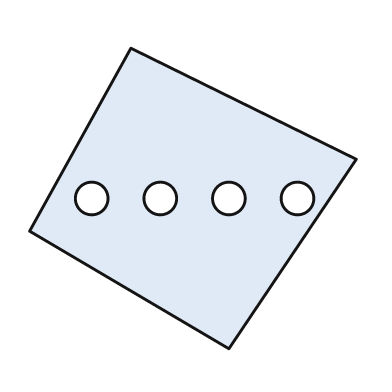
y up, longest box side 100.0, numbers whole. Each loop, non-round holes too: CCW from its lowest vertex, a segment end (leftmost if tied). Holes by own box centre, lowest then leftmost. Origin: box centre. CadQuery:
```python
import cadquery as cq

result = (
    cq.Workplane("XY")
    .moveTo(11.0, -46.0)
    .lineTo(50.0, 12.0)
    .lineTo(-19.0, 46.0)
    .lineTo(-50.0, -10.0)
    .close()
    .moveTo(-31.0, 0.0)
    .circle(5.0)
    .moveTo(-10.0, 0.0)
    .circle(5.0)
    .moveTo(11.0, 0.0)
    .circle(5.0)
    .moveTo(32.0, 0.0)
    .circle(5.0)
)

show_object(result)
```